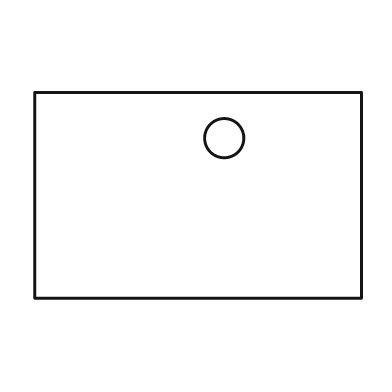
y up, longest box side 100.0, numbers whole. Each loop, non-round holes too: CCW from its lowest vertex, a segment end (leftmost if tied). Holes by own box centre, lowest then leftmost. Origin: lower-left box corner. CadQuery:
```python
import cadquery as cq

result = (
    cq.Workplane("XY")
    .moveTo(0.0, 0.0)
    .lineTo(100.0, 0.0)
    .lineTo(100.0, 63.0)
    .lineTo(0.0, 63.0)
    .close()
    .moveTo(58.0, 49.0)
    .circle(6.0)
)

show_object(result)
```